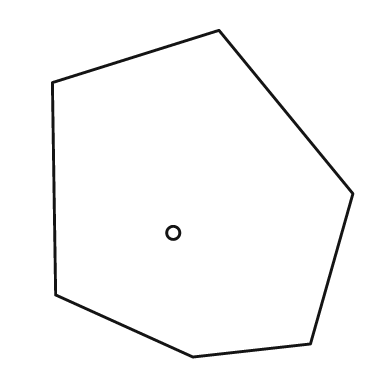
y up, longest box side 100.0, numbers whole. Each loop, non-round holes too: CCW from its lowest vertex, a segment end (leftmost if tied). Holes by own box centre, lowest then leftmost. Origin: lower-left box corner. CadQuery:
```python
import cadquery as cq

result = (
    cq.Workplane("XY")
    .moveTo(43.0, 0.0)
    .lineTo(79.0, 4.0)
    .lineTo(92.0, 50.0)
    .lineTo(51.0, 100.0)
    .lineTo(0.0, 84.0)
    .lineTo(1.0, 19.0)
    .close()
    .moveTo(37.0, 38.0)
    .circle(2.0)
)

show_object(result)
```